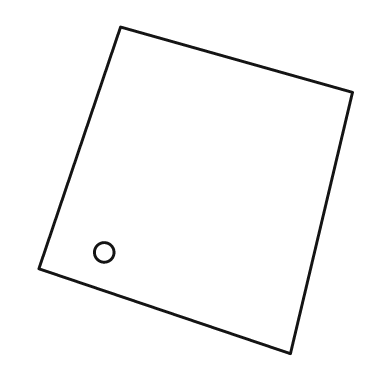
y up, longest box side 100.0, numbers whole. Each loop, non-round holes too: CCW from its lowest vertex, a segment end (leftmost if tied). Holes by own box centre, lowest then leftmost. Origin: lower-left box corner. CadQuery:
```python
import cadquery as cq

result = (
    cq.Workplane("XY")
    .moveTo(77.0, 0.0)
    .lineTo(96.0, 80.0)
    .lineTo(25.0, 100.0)
    .lineTo(0.0, 26.0)
    .close()
    .moveTo(20.0, 31.0)
    .circle(3.0)
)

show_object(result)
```